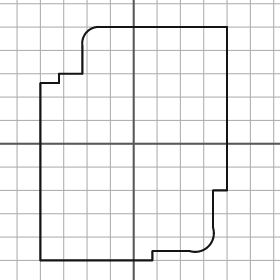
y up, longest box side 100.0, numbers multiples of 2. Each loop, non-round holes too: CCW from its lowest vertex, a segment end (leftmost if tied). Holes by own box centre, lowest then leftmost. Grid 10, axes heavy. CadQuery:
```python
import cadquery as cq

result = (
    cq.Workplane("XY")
    .moveTo(-40.0, -50.0)
    .lineTo(8.0, -50.0)
    .lineTo(8.0, -46.0)
    .lineTo(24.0, -46.0)
    .threePointArc((32.0, -44.0), (34.0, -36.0))
    .lineTo(34.0, -20.0)
    .lineTo(40.0, -20.0)
    .lineTo(40.0, 50.0)
    .lineTo(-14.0, 50.0)
    .threePointArc((-20.0, 48.0), (-22.0, 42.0))
    .lineTo(-22.0, 30.0)
    .lineTo(-32.0, 30.0)
    .lineTo(-32.0, 26.0)
    .lineTo(-40.0, 26.0)
    .close()
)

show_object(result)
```